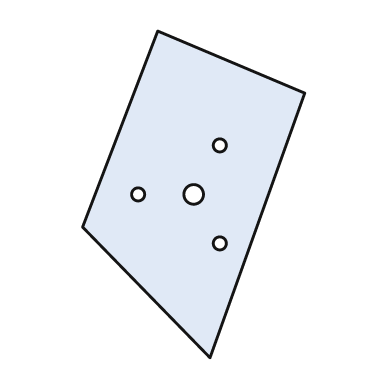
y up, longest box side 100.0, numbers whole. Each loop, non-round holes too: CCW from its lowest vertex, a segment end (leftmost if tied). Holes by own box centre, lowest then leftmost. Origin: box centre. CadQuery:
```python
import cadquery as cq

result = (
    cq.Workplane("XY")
    .moveTo(5.0, -50.0)
    .lineTo(34.0, 31.0)
    .lineTo(-11.0, 50.0)
    .lineTo(-34.0, -10.0)
    .close()
    .moveTo(8.0, -15.0)
    .circle(2.0)
    .moveTo(-17.0, 0.0)
    .circle(2.0)
    .moveTo(0.0, 0.0)
    .circle(3.0)
    .moveTo(8.0, 15.0)
    .circle(2.0)
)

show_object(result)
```